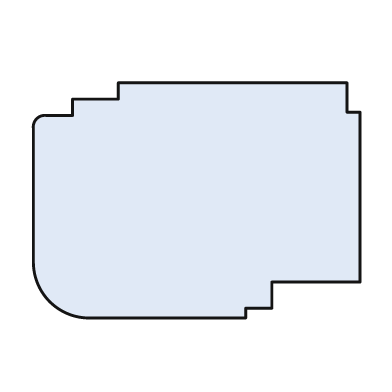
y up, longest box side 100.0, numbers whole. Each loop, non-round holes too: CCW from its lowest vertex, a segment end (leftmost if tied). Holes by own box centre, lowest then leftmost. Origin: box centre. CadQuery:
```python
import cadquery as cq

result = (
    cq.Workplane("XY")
    .moveTo(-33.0, -36.0)
    .lineTo(15.0, -36.0)
    .lineTo(15.0, -33.0)
    .lineTo(23.0, -33.0)
    .lineTo(23.0, -25.0)
    .lineTo(50.0, -25.0)
    .lineTo(50.0, 27.0)
    .lineTo(46.0, 27.0)
    .lineTo(46.0, 36.0)
    .lineTo(-24.0, 36.0)
    .lineTo(-24.0, 31.0)
    .lineTo(-38.0, 31.0)
    .lineTo(-38.0, 26.0)
    .lineTo(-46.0, 26.0)
    .threePointArc((-49.0, 25.0), (-50.0, 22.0))
    .lineTo(-50.0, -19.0)
    .threePointArc((-45.0, -31.0), (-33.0, -36.0))
    .close()
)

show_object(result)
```